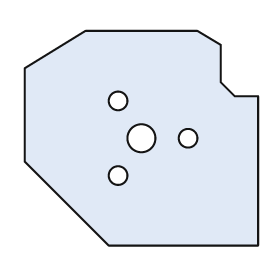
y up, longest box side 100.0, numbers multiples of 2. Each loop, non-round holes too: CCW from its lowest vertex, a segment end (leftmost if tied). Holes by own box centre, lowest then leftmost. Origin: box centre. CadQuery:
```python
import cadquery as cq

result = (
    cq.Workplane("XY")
    .moveTo(-14.0, -46.0)
    .lineTo(50.0, -46.0)
    .lineTo(50.0, 18.0)
    .lineTo(40.0, 18.0)
    .lineTo(34.0, 24.0)
    .lineTo(34.0, 40.0)
    .lineTo(24.0, 46.0)
    .lineTo(-24.0, 46.0)
    .lineTo(-50.0, 30.0)
    .lineTo(-50.0, -10.0)
    .close()
    .moveTo(-10.0, -16.0)
    .circle(4.0)
    .moveTo(0.0, 0.0)
    .circle(6.0)
    .moveTo(20.0, 0.0)
    .circle(4.0)
    .moveTo(-10.0, 16.0)
    .circle(4.0)
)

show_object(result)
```